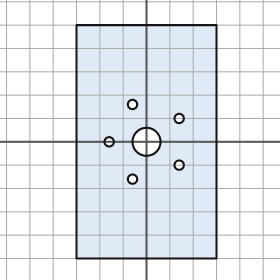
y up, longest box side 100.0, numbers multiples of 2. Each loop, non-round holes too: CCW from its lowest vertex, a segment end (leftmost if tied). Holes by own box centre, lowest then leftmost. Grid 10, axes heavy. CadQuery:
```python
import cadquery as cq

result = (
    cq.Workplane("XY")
    .moveTo(-30.0, -50.0)
    .lineTo(30.0, -50.0)
    .lineTo(30.0, 50.0)
    .lineTo(-30.0, 50.0)
    .close()
    .moveTo(-6.0, -16.0)
    .circle(2.0)
    .moveTo(14.0, -10.0)
    .circle(2.0)
    .moveTo(-16.0, 0.0)
    .circle(2.0)
    .moveTo(0.0, 0.0)
    .circle(6.0)
    .moveTo(14.0, 10.0)
    .circle(2.0)
    .moveTo(-6.0, 16.0)
    .circle(2.0)
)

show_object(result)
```